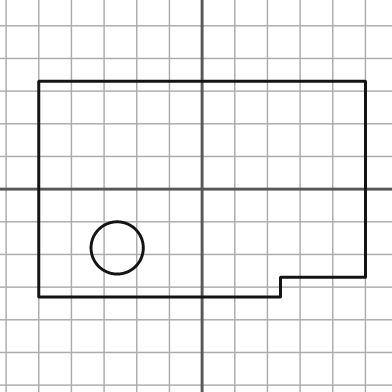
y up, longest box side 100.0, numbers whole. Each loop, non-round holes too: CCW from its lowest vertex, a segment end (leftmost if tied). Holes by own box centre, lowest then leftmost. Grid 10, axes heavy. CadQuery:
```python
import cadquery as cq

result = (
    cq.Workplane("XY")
    .moveTo(-50.0, -33.0)
    .lineTo(24.0, -33.0)
    .lineTo(24.0, -27.0)
    .lineTo(50.0, -27.0)
    .lineTo(50.0, 33.0)
    .lineTo(-50.0, 33.0)
    .close()
    .moveTo(-26.0, -18.0)
    .circle(8.0)
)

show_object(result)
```